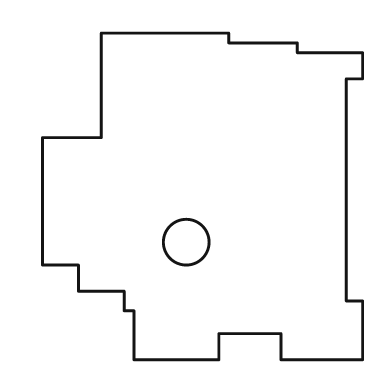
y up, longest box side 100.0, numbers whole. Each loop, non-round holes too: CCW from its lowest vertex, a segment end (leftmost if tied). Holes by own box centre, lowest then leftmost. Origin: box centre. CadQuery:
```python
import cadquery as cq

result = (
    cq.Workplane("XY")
    .moveTo(-21.0, -50.0)
    .lineTo(5.0, -50.0)
    .lineTo(5.0, -42.0)
    .lineTo(24.0, -42.0)
    .lineTo(24.0, -50.0)
    .lineTo(49.0, -50.0)
    .lineTo(49.0, -32.0)
    .lineTo(44.0, -32.0)
    .lineTo(44.0, 36.0)
    .lineTo(49.0, 36.0)
    .lineTo(49.0, 44.0)
    .lineTo(29.0, 44.0)
    .lineTo(29.0, 47.0)
    .lineTo(8.0, 47.0)
    .lineTo(8.0, 50.0)
    .lineTo(-31.0, 50.0)
    .lineTo(-31.0, 18.0)
    .lineTo(-49.0, 18.0)
    .lineTo(-49.0, -21.0)
    .lineTo(-38.0, -21.0)
    .lineTo(-38.0, -29.0)
    .lineTo(-24.0, -29.0)
    .lineTo(-24.0, -35.0)
    .lineTo(-21.0, -35.0)
    .close()
    .moveTo(-5.0, -14.0)
    .circle(7.0)
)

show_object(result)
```